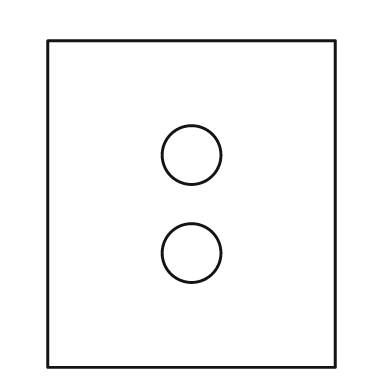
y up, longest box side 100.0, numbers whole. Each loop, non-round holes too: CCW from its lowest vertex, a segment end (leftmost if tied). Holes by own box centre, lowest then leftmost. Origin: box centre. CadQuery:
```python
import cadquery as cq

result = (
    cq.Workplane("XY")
    .moveTo(-44.0, -50.0)
    .lineTo(44.0, -50.0)
    .lineTo(44.0, 50.0)
    .lineTo(-44.0, 50.0)
    .close()
    .moveTo(0.0, -15.0)
    .circle(9.0)
    .moveTo(0.0, 15.0)
    .circle(9.0)
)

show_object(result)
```